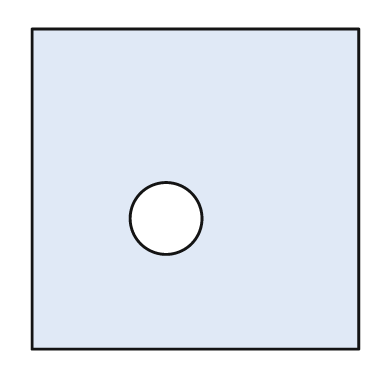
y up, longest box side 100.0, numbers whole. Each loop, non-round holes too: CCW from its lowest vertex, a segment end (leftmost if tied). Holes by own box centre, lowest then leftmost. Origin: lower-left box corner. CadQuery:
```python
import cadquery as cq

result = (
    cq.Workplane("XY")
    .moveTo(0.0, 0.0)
    .lineTo(100.0, 0.0)
    .lineTo(100.0, 98.0)
    .lineTo(0.0, 98.0)
    .close()
    .moveTo(41.0, 40.0)
    .circle(11.0)
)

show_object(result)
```